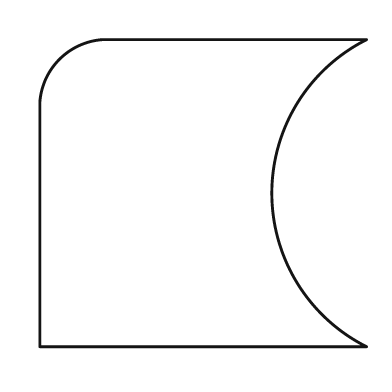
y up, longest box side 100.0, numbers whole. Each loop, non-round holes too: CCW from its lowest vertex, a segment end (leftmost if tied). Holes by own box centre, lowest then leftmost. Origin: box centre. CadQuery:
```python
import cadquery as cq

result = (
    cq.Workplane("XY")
    .moveTo(-50.0, -47.0)
    .lineTo(50.0, -47.0)
    .threePointArc((21.0, 0.0), (50.0, 47.0))
    .lineTo(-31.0, 47.0)
    .threePointArc((-44.0, 41.0), (-50.0, 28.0))
    .close()
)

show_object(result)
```